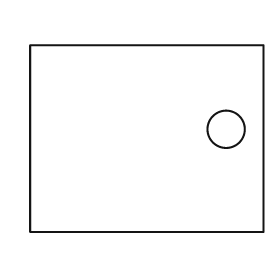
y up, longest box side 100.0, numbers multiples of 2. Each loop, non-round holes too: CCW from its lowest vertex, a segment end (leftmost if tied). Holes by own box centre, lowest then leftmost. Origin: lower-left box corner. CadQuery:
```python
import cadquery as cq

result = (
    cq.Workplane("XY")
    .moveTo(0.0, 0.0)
    .lineTo(100.0, 0.0)
    .lineTo(100.0, 80.0)
    .lineTo(0.0, 80.0)
    .close()
    .moveTo(84.0, 44.0)
    .circle(8.0)
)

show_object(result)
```